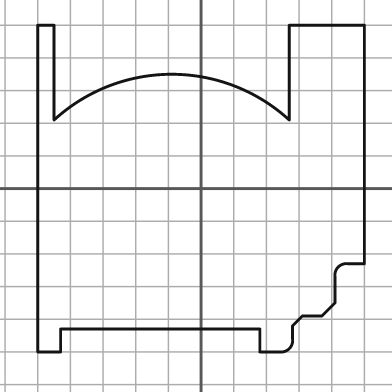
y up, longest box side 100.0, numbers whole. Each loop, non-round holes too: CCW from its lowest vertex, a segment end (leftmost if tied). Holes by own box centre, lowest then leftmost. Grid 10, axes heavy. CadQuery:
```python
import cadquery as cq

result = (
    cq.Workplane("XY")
    .moveTo(-50.0, -50.0)
    .lineTo(-43.0, -50.0)
    .lineTo(-43.0, -43.0)
    .lineTo(18.0, -43.0)
    .lineTo(18.0, -50.0)
    .lineTo(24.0, -50.0)
    .threePointArc((27.0, -49.0), (28.0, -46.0))
    .lineTo(28.0, -42.0)
    .lineTo(31.0, -39.0)
    .lineTo(37.0, -39.0)
    .lineTo(41.0, -35.0)
    .lineTo(41.0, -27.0)
    .threePointArc((42.0, -24.0), (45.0, -23.0))
    .lineTo(50.0, -23.0)
    .lineTo(50.0, 50.0)
    .lineTo(27.0, 50.0)
    .lineTo(27.0, 21.0)
    .threePointArc((-9.0, 35.0), (-45.0, 21.0))
    .lineTo(-45.0, 50.0)
    .lineTo(-50.0, 50.0)
    .close()
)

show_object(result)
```